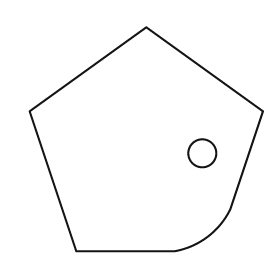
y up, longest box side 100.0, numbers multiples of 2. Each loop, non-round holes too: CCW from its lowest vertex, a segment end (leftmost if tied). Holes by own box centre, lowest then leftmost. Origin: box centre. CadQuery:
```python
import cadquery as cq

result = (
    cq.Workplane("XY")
    .moveTo(-30.0, -48.0)
    .lineTo(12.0, -48.0)
    .threePointArc((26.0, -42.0), (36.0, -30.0))
    .lineTo(50.0, 12.0)
    .lineTo(0.0, 48.0)
    .lineTo(-50.0, 12.0)
    .close()
    .moveTo(24.0, -6.0)
    .circle(6.0)
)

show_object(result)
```